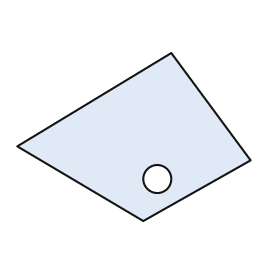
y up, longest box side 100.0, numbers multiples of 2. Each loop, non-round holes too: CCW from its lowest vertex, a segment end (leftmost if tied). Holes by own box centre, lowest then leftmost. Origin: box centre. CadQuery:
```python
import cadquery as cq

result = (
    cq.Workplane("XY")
    .moveTo(4.0, -36.0)
    .lineTo(50.0, -10.0)
    .lineTo(16.0, 36.0)
    .lineTo(-50.0, -4.0)
    .close()
    .moveTo(10.0, -18.0)
    .circle(6.0)
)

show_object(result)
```